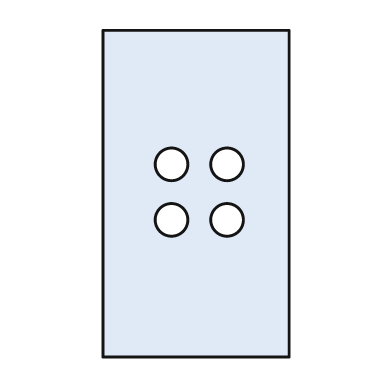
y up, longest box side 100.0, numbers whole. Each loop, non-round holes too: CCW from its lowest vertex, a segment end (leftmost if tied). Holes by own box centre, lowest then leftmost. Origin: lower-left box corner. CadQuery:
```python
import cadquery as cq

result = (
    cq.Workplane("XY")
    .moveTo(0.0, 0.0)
    .lineTo(57.0, 0.0)
    .lineTo(57.0, 100.0)
    .lineTo(0.0, 100.0)
    .close()
    .moveTo(21.0, 42.0)
    .circle(5.0)
    .moveTo(38.0, 42.0)
    .circle(5.0)
    .moveTo(21.0, 59.0)
    .circle(5.0)
    .moveTo(38.0, 59.0)
    .circle(5.0)
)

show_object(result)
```